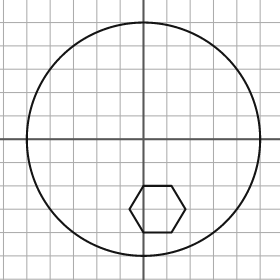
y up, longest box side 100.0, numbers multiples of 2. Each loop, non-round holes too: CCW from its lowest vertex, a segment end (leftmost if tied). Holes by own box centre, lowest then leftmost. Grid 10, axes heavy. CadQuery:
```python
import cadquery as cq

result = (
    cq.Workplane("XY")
    .moveTo(0.0, 0.0)
    .circle(50.0)
    .moveTo(0.0, -40.0)
    .lineTo(12.0, -40.0)
    .lineTo(18.0, -30.0)
    .lineTo(12.0, -20.0)
    .lineTo(0.0, -20.0)
    .lineTo(-6.0, -30.0)
    .close()
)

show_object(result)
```